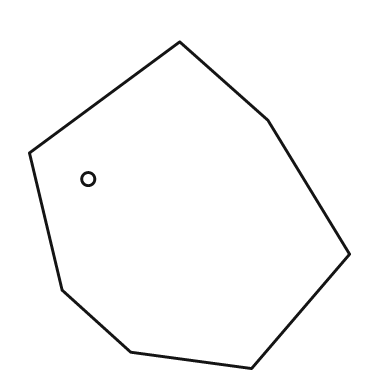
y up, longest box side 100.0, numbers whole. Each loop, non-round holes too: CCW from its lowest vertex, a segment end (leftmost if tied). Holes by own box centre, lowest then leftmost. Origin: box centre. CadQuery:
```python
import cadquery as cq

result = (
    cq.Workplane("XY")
    .moveTo(19.0, -50.0)
    .lineTo(49.0, -15.0)
    .lineTo(24.0, 26.0)
    .lineTo(-3.0, 50.0)
    .lineTo(-49.0, 16.0)
    .lineTo(-39.0, -26.0)
    .lineTo(-18.0, -45.0)
    .close()
    .moveTo(-31.0, 8.0)
    .circle(2.0)
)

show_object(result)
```